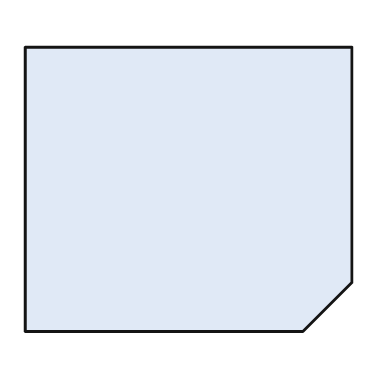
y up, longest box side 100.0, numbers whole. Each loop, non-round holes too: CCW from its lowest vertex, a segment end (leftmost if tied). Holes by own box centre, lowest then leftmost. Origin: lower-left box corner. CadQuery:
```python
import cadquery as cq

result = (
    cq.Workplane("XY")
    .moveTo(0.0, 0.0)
    .lineTo(85.0, 0.0)
    .lineTo(100.0, 15.0)
    .lineTo(100.0, 87.0)
    .lineTo(0.0, 87.0)
    .close()
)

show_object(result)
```